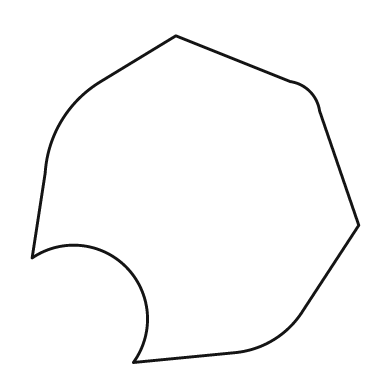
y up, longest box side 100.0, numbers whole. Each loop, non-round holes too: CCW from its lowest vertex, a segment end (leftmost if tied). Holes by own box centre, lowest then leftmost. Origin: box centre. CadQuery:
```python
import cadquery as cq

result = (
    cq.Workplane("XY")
    .moveTo(-19.0, -50.0)
    .lineTo(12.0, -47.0)
    .threePointArc((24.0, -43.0), (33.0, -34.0))
    .lineTo(50.0, -8.0)
    .lineTo(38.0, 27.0)
    .threePointArc((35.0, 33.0), (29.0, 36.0))
    .lineTo(-6.0, 50.0)
    .lineTo(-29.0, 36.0)
    .threePointArc((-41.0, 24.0), (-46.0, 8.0))
    .lineTo(-50.0, -18.0)
    .threePointArc((-21.0, -21.0), (-19.0, -50.0))
    .close()
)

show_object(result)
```